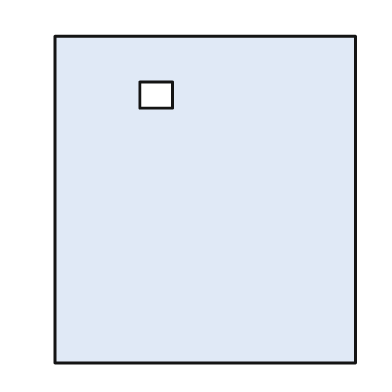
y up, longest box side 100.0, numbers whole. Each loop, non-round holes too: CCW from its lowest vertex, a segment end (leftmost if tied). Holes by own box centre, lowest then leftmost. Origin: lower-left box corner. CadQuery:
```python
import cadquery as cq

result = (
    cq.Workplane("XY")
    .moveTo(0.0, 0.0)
    .lineTo(92.0, 0.0)
    .lineTo(92.0, 100.0)
    .lineTo(0.0, 100.0)
    .close()
    .moveTo(26.0, 78.0)
    .lineTo(36.0, 78.0)
    .lineTo(36.0, 86.0)
    .lineTo(26.0, 86.0)
    .close()
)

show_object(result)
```